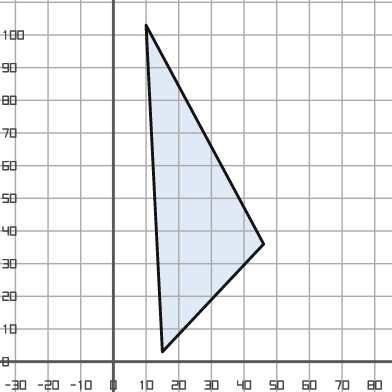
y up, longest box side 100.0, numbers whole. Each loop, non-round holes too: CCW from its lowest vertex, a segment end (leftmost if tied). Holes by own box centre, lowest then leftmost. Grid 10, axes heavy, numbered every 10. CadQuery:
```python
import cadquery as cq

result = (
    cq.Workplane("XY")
    .moveTo(15.0, 3.0)
    .lineTo(46.0, 36.0)
    .lineTo(10.0, 103.0)
    .close()
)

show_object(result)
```